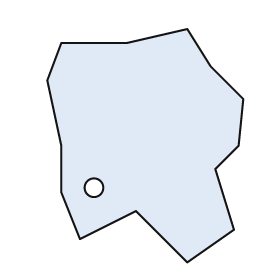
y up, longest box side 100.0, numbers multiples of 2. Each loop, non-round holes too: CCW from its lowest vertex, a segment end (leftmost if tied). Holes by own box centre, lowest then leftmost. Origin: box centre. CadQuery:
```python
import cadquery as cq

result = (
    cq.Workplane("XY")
    .moveTo(18.0, -50.0)
    .lineTo(38.0, -36.0)
    .lineTo(30.0, -10.0)
    .lineTo(40.0, 0.0)
    .lineTo(42.0, 20.0)
    .lineTo(28.0, 34.0)
    .lineTo(18.0, 50.0)
    .lineTo(-8.0, 44.0)
    .lineTo(-36.0, 44.0)
    .lineTo(-42.0, 28.0)
    .lineTo(-36.0, 0.0)
    .lineTo(-36.0, -20.0)
    .lineTo(-28.0, -40.0)
    .lineTo(-4.0, -28.0)
    .close()
    .moveTo(-22.0, -18.0)
    .circle(4.0)
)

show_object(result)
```